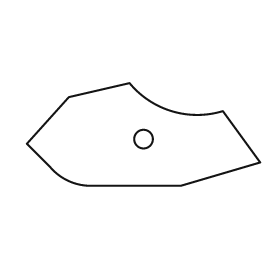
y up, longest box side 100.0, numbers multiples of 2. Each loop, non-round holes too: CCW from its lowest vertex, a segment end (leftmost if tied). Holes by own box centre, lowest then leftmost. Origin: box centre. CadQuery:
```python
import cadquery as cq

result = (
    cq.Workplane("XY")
    .moveTo(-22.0, -22.0)
    .lineTo(16.0, -22.0)
    .lineTo(50.0, -12.0)
    .lineTo(34.0, 10.0)
    .threePointArc((12.0, 10.0), (-6.0, 22.0))
    .lineTo(-32.0, 16.0)
    .lineTo(-50.0, -4.0)
    .lineTo(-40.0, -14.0)
    .threePointArc((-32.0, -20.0), (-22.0, -22.0))
    .close()
    .moveTo(0.0, -2.0)
    .circle(4.0)
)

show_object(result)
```